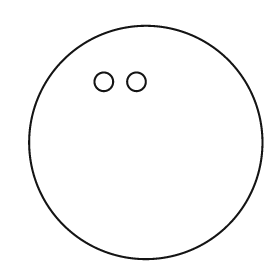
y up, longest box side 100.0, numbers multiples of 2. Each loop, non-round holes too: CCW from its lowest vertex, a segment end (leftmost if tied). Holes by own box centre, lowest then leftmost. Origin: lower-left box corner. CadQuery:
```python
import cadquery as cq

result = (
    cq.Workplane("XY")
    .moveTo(50.0, 50.0)
    .circle(50.0)
    .moveTo(32.0, 76.0)
    .circle(4.0)
    .moveTo(46.0, 76.0)
    .circle(4.0)
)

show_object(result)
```